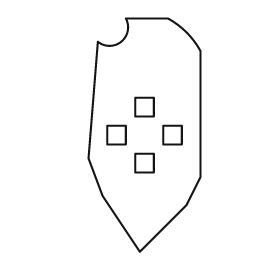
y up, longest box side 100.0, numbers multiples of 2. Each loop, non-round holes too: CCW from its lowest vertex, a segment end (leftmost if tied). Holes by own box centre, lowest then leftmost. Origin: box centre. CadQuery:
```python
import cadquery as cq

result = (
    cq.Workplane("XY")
    .moveTo(-2.0, -50.0)
    .lineTo(18.0, -30.0)
    .lineTo(24.0, -18.0)
    .lineTo(24.0, 36.0)
    .threePointArc((18.0, 44.0), (10.0, 50.0))
    .lineTo(-8.0, 50.0)
    .threePointArc((-10.0, 40.0), (-20.0, 40.0))
    .lineTo(-24.0, -10.0)
    .lineTo(-18.0, -26.0)
    .close()
    .moveTo(-4.0, -16.0)
    .lineTo(4.0, -16.0)
    .lineTo(4.0, -8.0)
    .lineTo(-4.0, -8.0)
    .close()
    .moveTo(-16.0, -4.0)
    .lineTo(-8.0, -4.0)
    .lineTo(-8.0, 4.0)
    .lineTo(-16.0, 4.0)
    .close()
    .moveTo(8.0, -4.0)
    .lineTo(16.0, -4.0)
    .lineTo(16.0, 4.0)
    .lineTo(8.0, 4.0)
    .close()
    .moveTo(-4.0, 8.0)
    .lineTo(4.0, 8.0)
    .lineTo(4.0, 16.0)
    .lineTo(-4.0, 16.0)
    .close()
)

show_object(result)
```